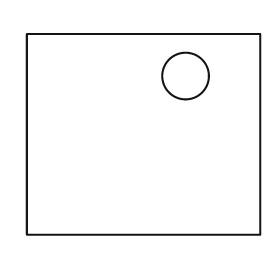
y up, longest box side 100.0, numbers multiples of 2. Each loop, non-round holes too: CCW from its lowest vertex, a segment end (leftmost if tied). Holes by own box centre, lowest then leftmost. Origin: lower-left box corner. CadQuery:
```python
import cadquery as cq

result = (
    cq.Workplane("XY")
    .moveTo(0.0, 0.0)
    .lineTo(100.0, 0.0)
    .lineTo(100.0, 86.0)
    .lineTo(0.0, 86.0)
    .close()
    .moveTo(68.0, 68.0)
    .circle(10.0)
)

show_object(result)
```